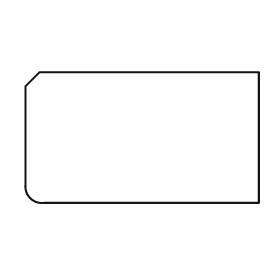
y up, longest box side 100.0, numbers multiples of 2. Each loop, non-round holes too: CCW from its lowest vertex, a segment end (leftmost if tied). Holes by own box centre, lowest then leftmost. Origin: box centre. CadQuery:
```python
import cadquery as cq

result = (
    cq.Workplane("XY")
    .moveTo(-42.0, -28.0)
    .lineTo(50.0, -28.0)
    .lineTo(50.0, 28.0)
    .lineTo(-44.0, 28.0)
    .lineTo(-50.0, 22.0)
    .lineTo(-50.0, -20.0)
    .threePointArc((-48.0, -26.0), (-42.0, -28.0))
    .close()
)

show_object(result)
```